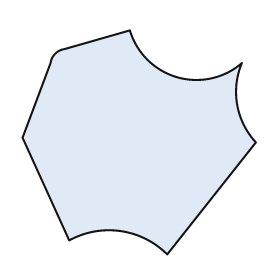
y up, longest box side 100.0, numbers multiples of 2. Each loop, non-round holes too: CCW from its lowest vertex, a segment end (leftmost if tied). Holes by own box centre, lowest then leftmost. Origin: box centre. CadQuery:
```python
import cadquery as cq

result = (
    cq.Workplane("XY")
    .moveTo(12.0, -48.0)
    .lineTo(50.0, 0.0)
    .threePointArc((42.0, 16.0), (44.0, 34.0))
    .threePointArc((16.0, 28.0), (-4.0, 48.0))
    .lineTo(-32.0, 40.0)
    .threePointArc((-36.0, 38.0), (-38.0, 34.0))
    .lineTo(-50.0, 2.0)
    .lineTo(-30.0, -42.0)
    .threePointArc((-8.0, -38.0), (12.0, -48.0))
    .close()
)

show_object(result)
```